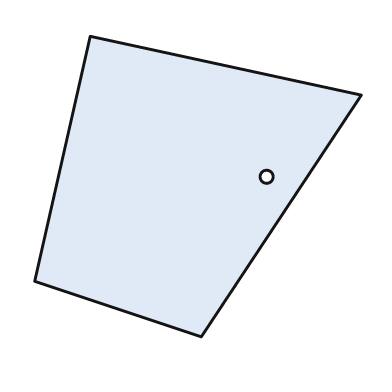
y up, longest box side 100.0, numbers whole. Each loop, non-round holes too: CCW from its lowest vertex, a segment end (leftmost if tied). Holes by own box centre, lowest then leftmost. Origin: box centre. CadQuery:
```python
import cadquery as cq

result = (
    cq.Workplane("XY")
    .moveTo(1.0, -46.0)
    .lineTo(50.0, 28.0)
    .lineTo(-33.0, 46.0)
    .lineTo(-50.0, -29.0)
    .close()
    .moveTo(21.0, 3.0)
    .circle(2.0)
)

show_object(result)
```